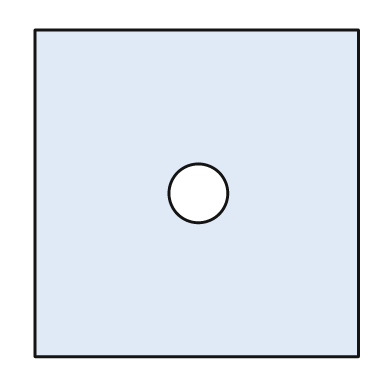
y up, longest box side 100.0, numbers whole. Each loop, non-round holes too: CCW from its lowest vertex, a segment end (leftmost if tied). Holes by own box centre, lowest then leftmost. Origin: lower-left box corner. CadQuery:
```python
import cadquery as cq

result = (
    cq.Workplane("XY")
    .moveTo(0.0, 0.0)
    .lineTo(99.0, 0.0)
    .lineTo(99.0, 100.0)
    .lineTo(0.0, 100.0)
    .close()
    .moveTo(50.0, 50.0)
    .circle(9.0)
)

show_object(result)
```